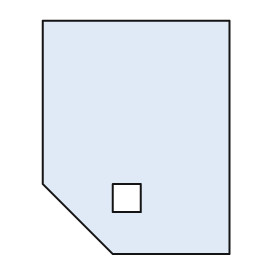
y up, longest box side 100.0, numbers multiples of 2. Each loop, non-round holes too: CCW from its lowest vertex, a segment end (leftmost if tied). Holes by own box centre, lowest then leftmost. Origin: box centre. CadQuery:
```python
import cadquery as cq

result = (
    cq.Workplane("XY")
    .moveTo(-10.0, -50.0)
    .lineTo(40.0, -50.0)
    .lineTo(40.0, 50.0)
    .lineTo(-40.0, 50.0)
    .lineTo(-40.0, -20.0)
    .close()
    .moveTo(-10.0, -32.0)
    .lineTo(2.0, -32.0)
    .lineTo(2.0, -20.0)
    .lineTo(-10.0, -20.0)
    .close()
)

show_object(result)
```